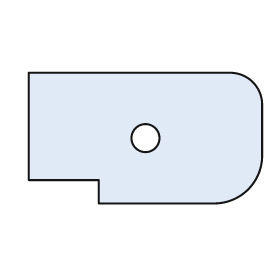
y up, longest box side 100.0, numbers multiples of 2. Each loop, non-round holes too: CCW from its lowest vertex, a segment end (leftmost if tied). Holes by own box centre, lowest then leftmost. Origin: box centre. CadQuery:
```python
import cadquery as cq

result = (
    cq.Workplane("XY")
    .moveTo(-20.0, -28.0)
    .lineTo(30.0, -28.0)
    .threePointArc((44.0, -22.0), (50.0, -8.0))
    .lineTo(50.0, 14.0)
    .threePointArc((46.0, 24.0), (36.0, 28.0))
    .lineTo(-50.0, 28.0)
    .lineTo(-50.0, -18.0)
    .lineTo(-20.0, -18.0)
    .close()
    .moveTo(0.0, 0.0)
    .circle(6.0)
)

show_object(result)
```